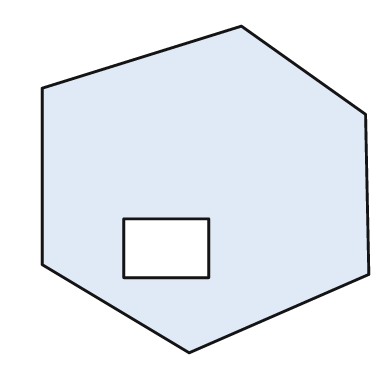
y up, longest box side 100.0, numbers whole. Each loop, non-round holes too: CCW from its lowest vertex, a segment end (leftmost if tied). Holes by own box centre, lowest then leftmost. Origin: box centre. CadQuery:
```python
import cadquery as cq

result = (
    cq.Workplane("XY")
    .moveTo(-5.0, -50.0)
    .lineTo(50.0, -26.0)
    .lineTo(49.0, 23.0)
    .lineTo(11.0, 50.0)
    .lineTo(-50.0, 31.0)
    .lineTo(-50.0, -23.0)
    .close()
    .moveTo(-25.0, -27.0)
    .lineTo(1.0, -27.0)
    .lineTo(1.0, -9.0)
    .lineTo(-25.0, -9.0)
    .close()
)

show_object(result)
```